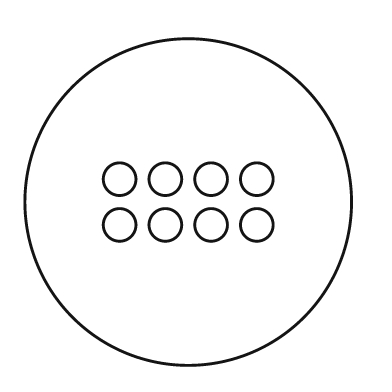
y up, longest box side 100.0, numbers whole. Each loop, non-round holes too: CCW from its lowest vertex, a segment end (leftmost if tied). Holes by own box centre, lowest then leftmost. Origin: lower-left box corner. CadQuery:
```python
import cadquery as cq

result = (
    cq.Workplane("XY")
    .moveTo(50.0, 50.0)
    .circle(50.0)
    .moveTo(29.0, 43.0)
    .circle(5.0)
    .moveTo(43.0, 43.0)
    .circle(5.0)
    .moveTo(57.0, 43.0)
    .circle(5.0)
    .moveTo(71.0, 43.0)
    .circle(5.0)
    .moveTo(29.0, 57.0)
    .circle(5.0)
    .moveTo(43.0, 57.0)
    .circle(5.0)
    .moveTo(57.0, 57.0)
    .circle(5.0)
    .moveTo(71.0, 57.0)
    .circle(5.0)
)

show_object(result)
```